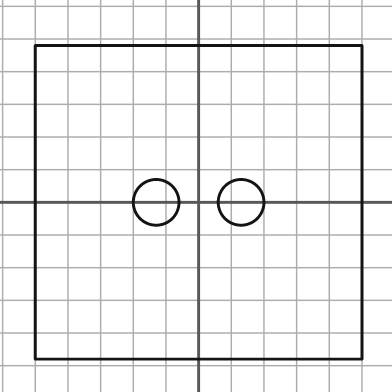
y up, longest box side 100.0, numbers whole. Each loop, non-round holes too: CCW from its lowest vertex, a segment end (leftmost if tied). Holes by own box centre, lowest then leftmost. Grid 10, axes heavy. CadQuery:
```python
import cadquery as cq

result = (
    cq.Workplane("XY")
    .moveTo(-50.0, -48.0)
    .lineTo(50.0, -48.0)
    .lineTo(50.0, 48.0)
    .lineTo(-50.0, 48.0)
    .close()
    .moveTo(-13.0, 0.0)
    .circle(7.0)
    .moveTo(13.0, 0.0)
    .circle(7.0)
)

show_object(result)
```